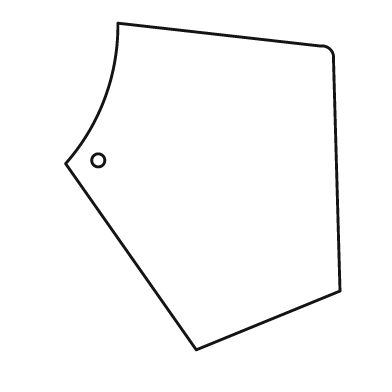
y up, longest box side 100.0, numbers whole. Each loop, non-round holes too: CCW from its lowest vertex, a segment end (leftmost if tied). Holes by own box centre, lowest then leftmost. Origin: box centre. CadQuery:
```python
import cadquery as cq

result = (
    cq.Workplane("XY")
    .moveTo(-2.0, -50.0)
    .lineTo(42.0, -32.0)
    .lineTo(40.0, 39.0)
    .threePointArc((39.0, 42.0), (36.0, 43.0))
    .lineTo(-26.0, 50.0)
    .threePointArc((-30.0, 27.0), (-42.0, 7.0))
    .close()
    .moveTo(-32.0, 8.0)
    .circle(2.0)
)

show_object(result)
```